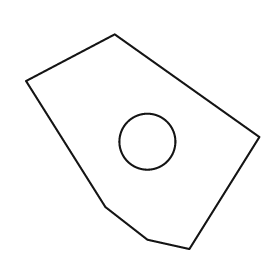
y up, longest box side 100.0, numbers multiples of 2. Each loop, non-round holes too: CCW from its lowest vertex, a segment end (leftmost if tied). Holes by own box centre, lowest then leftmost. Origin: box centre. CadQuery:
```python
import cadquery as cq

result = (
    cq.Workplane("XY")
    .moveTo(20.0, -46.0)
    .lineTo(50.0, 2.0)
    .lineTo(-12.0, 46.0)
    .lineTo(-50.0, 26.0)
    .lineTo(-16.0, -28.0)
    .lineTo(2.0, -42.0)
    .close()
    .moveTo(2.0, 0.0)
    .circle(12.0)
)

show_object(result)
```